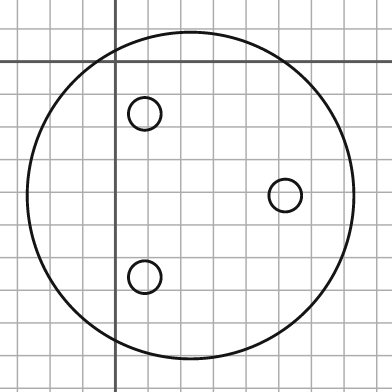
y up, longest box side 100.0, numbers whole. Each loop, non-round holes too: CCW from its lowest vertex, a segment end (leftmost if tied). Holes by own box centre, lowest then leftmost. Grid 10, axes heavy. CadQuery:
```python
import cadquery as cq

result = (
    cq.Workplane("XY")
    .moveTo(23.0, -41.0)
    .circle(50.0)
    .moveTo(9.0, -66.0)
    .circle(5.0)
    .moveTo(52.0, -41.0)
    .circle(5.0)
    .moveTo(9.0, -16.0)
    .circle(5.0)
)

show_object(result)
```